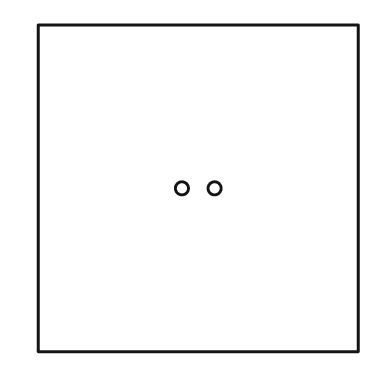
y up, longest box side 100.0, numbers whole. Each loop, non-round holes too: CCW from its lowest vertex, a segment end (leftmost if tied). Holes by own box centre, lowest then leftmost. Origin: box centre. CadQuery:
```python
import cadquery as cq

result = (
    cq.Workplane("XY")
    .moveTo(-49.0, -50.0)
    .lineTo(49.0, -50.0)
    .lineTo(49.0, 50.0)
    .lineTo(-49.0, 50.0)
    .close()
    .moveTo(-5.0, 0.0)
    .circle(2.0)
    .moveTo(5.0, 0.0)
    .circle(2.0)
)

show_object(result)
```